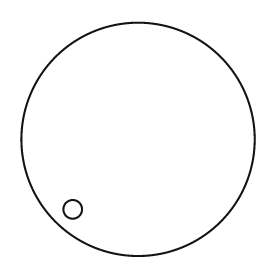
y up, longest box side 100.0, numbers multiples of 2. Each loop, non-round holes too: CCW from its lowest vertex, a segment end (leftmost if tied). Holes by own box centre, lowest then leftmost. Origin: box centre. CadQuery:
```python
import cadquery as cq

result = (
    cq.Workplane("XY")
    .moveTo(0.0, 0.0)
    .circle(50.0)
    .moveTo(-28.0, -30.0)
    .circle(4.0)
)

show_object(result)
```